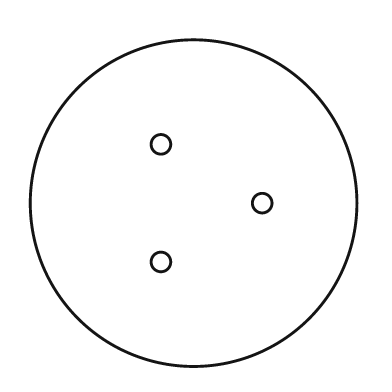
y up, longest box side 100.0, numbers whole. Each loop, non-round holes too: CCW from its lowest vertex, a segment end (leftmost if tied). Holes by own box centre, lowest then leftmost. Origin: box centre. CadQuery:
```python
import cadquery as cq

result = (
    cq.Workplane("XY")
    .moveTo(0.0, 0.0)
    .circle(50.0)
    .moveTo(-10.0, -18.0)
    .circle(3.0)
    .moveTo(21.0, 0.0)
    .circle(3.0)
    .moveTo(-10.0, 18.0)
    .circle(3.0)
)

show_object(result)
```